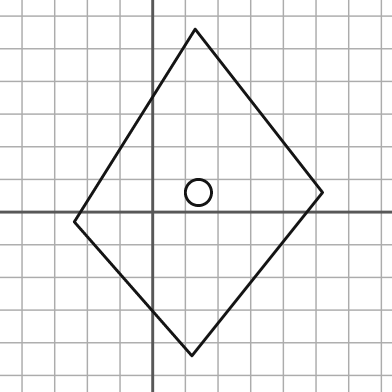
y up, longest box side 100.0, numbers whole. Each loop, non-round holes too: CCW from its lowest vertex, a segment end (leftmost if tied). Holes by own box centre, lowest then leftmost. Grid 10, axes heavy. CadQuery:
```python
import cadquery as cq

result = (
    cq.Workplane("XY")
    .moveTo(12.0, -44.0)
    .lineTo(52.0, 6.0)
    .lineTo(13.0, 56.0)
    .lineTo(-24.0, -3.0)
    .close()
    .moveTo(14.0, 6.0)
    .circle(4.0)
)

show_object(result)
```